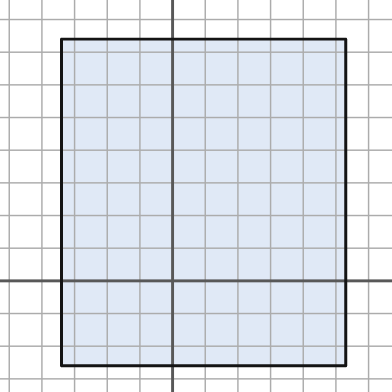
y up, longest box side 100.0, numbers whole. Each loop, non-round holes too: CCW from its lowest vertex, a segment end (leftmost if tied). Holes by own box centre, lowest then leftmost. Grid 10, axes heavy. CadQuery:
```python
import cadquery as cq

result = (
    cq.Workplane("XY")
    .moveTo(-34.0, -26.0)
    .lineTo(53.0, -26.0)
    .lineTo(53.0, 74.0)
    .lineTo(-34.0, 74.0)
    .close()
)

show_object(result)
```